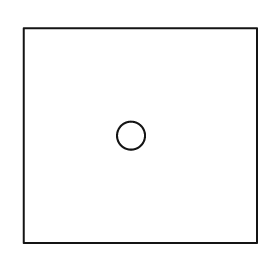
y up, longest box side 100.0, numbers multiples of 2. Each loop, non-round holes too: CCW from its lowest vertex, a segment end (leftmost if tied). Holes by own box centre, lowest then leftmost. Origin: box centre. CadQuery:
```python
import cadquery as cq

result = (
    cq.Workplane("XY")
    .moveTo(-50.0, -46.0)
    .lineTo(50.0, -46.0)
    .lineTo(50.0, 46.0)
    .lineTo(-50.0, 46.0)
    .close()
    .moveTo(-4.0, 0.0)
    .circle(6.0)
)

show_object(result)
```